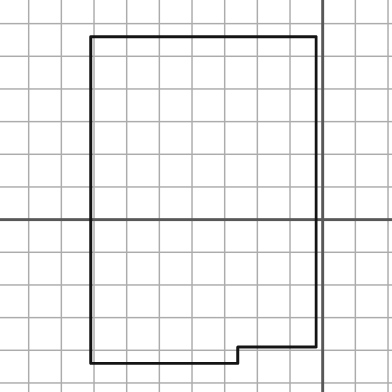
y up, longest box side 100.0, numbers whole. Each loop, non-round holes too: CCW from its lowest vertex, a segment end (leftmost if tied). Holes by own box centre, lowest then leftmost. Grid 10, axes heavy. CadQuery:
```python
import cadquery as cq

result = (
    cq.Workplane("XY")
    .moveTo(-71.0, -44.0)
    .lineTo(-26.0, -44.0)
    .lineTo(-26.0, -39.0)
    .lineTo(-2.0, -39.0)
    .lineTo(-2.0, 56.0)
    .lineTo(-71.0, 56.0)
    .close()
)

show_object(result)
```